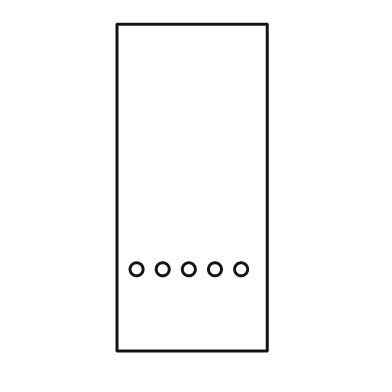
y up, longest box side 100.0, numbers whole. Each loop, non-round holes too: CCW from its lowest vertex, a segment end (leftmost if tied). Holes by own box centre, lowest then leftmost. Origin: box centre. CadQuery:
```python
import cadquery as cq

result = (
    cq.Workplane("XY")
    .moveTo(-23.0, -50.0)
    .lineTo(23.0, -50.0)
    .lineTo(23.0, 50.0)
    .lineTo(-23.0, 50.0)
    .close()
    .moveTo(-17.0, -25.0)
    .circle(2.0)
    .moveTo(-9.0, -25.0)
    .circle(2.0)
    .moveTo(-1.0, -25.0)
    .circle(2.0)
    .moveTo(7.0, -25.0)
    .circle(2.0)
    .moveTo(15.0, -25.0)
    .circle(2.0)
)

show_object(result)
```